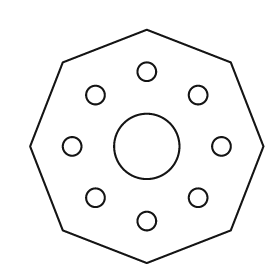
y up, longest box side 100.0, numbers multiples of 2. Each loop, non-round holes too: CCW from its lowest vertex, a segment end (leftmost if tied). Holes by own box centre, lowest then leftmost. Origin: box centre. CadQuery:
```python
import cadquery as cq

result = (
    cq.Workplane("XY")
    .moveTo(0.0, -50.0)
    .lineTo(36.0, -36.0)
    .lineTo(50.0, 0.0)
    .lineTo(36.0, 36.0)
    .lineTo(0.0, 50.0)
    .lineTo(-36.0, 36.0)
    .lineTo(-50.0, 0.0)
    .lineTo(-36.0, -36.0)
    .close()
    .moveTo(0.0, -32.0)
    .circle(4.0)
    .moveTo(-22.0, -22.0)
    .circle(4.0)
    .moveTo(22.0, -22.0)
    .circle(4.0)
    .moveTo(-32.0, 0.0)
    .circle(4.0)
    .moveTo(0.0, 0.0)
    .circle(14.0)
    .moveTo(32.0, 0.0)
    .circle(4.0)
    .moveTo(-22.0, 22.0)
    .circle(4.0)
    .moveTo(22.0, 22.0)
    .circle(4.0)
    .moveTo(0.0, 32.0)
    .circle(4.0)
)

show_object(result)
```